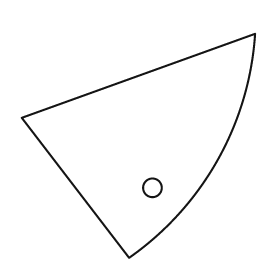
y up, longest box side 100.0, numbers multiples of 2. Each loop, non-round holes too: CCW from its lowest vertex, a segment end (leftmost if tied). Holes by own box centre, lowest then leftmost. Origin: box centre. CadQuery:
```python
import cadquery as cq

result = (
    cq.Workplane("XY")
    .moveTo(-4.0, -48.0)
    .threePointArc((34.0, -6.0), (50.0, 48.0))
    .lineTo(-50.0, 12.0)
    .close()
    .moveTo(6.0, -18.0)
    .circle(4.0)
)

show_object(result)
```